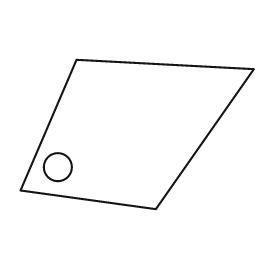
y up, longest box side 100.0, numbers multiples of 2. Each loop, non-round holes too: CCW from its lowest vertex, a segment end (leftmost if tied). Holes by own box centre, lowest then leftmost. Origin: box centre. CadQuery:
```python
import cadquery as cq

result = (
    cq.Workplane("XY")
    .moveTo(8.0, -32.0)
    .lineTo(50.0, 28.0)
    .lineTo(-26.0, 32.0)
    .lineTo(-50.0, -24.0)
    .close()
    .moveTo(-34.0, -14.0)
    .circle(6.0)
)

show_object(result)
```